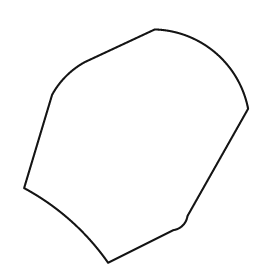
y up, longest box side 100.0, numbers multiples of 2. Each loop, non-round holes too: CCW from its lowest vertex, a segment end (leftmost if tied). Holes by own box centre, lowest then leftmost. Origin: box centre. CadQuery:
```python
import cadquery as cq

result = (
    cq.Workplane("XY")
    .moveTo(-12.0, -50.0)
    .lineTo(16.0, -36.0)
    .threePointArc((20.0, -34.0), (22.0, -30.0))
    .lineTo(48.0, 16.0)
    .threePointArc((34.0, 40.0), (8.0, 50.0))
    .lineTo(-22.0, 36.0)
    .threePointArc((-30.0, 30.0), (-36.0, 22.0))
    .lineTo(-48.0, -18.0)
    .threePointArc((-28.0, -32.0), (-12.0, -50.0))
    .close()
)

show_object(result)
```